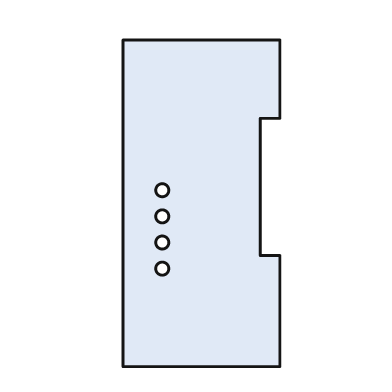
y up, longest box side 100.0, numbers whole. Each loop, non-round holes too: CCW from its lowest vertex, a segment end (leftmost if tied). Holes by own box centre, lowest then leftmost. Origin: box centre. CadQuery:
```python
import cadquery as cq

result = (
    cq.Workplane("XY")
    .moveTo(-24.0, -50.0)
    .lineTo(24.0, -50.0)
    .lineTo(24.0, -16.0)
    .lineTo(18.0, -16.0)
    .lineTo(18.0, 26.0)
    .lineTo(24.0, 26.0)
    .lineTo(24.0, 50.0)
    .lineTo(-24.0, 50.0)
    .close()
    .moveTo(-12.0, -20.0)
    .circle(2.0)
    .moveTo(-12.0, -12.0)
    .circle(2.0)
    .moveTo(-12.0, -4.0)
    .circle(2.0)
    .moveTo(-12.0, 4.0)
    .circle(2.0)
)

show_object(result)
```